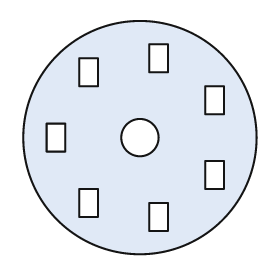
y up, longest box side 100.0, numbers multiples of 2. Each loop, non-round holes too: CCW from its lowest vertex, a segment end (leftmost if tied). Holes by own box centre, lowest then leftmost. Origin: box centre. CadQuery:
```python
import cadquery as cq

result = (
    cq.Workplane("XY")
    .moveTo(0.0, 0.0)
    .circle(50.0)
    .moveTo(4.0, -40.0)
    .lineTo(12.0, -40.0)
    .lineTo(12.0, -28.0)
    .lineTo(4.0, -28.0)
    .close()
    .moveTo(-26.0, -34.0)
    .lineTo(-18.0, -34.0)
    .lineTo(-18.0, -22.0)
    .lineTo(-26.0, -22.0)
    .close()
    .moveTo(28.0, -22.0)
    .lineTo(36.0, -22.0)
    .lineTo(36.0, -10.0)
    .lineTo(28.0, -10.0)
    .close()
    .moveTo(-40.0, -6.0)
    .lineTo(-32.0, -6.0)
    .lineTo(-32.0, 6.0)
    .lineTo(-40.0, 6.0)
    .close()
    .moveTo(0.0, 0.0)
    .circle(8.0)
    .moveTo(28.0, 10.0)
    .lineTo(36.0, 10.0)
    .lineTo(36.0, 22.0)
    .lineTo(28.0, 22.0)
    .close()
    .moveTo(-26.0, 22.0)
    .lineTo(-18.0, 22.0)
    .lineTo(-18.0, 34.0)
    .lineTo(-26.0, 34.0)
    .close()
    .moveTo(4.0, 28.0)
    .lineTo(12.0, 28.0)
    .lineTo(12.0, 40.0)
    .lineTo(4.0, 40.0)
    .close()
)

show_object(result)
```